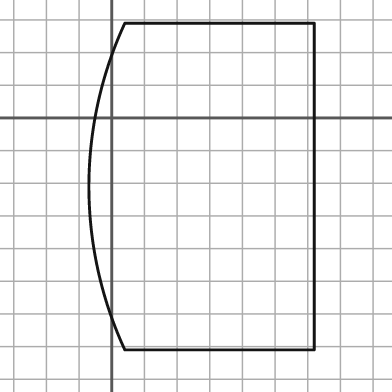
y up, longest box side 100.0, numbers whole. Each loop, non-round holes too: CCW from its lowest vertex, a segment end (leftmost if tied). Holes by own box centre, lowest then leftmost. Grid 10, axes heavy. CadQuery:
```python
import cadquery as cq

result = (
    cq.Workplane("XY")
    .moveTo(4.0, -71.0)
    .lineTo(62.0, -71.0)
    .lineTo(62.0, 29.0)
    .lineTo(4.0, 29.0)
    .threePointArc((-7.0, -21.0), (4.0, -71.0))
    .close()
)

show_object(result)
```